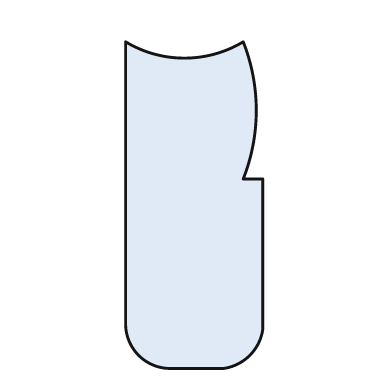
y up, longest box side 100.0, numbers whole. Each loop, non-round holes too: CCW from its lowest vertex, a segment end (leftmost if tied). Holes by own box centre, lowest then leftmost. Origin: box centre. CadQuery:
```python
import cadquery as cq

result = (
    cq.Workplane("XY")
    .moveTo(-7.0, -50.0)
    .lineTo(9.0, -50.0)
    .threePointArc((17.0, -46.0), (21.0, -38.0))
    .lineTo(21.0, 8.0)
    .lineTo(15.0, 8.0)
    .threePointArc((19.0, 29.0), (15.0, 50.0))
    .threePointArc((-3.0, 45.0), (-21.0, 50.0))
    .lineTo(-21.0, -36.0)
    .threePointArc((-17.0, -46.0), (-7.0, -50.0))
    .close()
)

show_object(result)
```